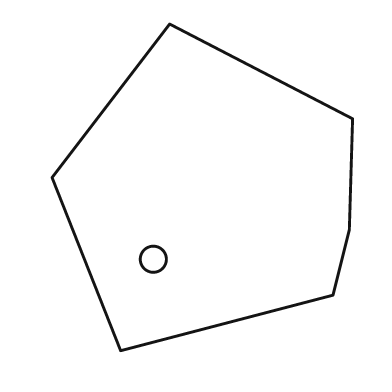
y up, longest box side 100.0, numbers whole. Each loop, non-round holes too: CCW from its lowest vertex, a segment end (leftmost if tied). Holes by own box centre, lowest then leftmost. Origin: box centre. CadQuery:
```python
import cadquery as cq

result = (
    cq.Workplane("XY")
    .moveTo(-25.0, -50.0)
    .lineTo(40.0, -33.0)
    .lineTo(45.0, -13.0)
    .lineTo(46.0, 21.0)
    .lineTo(-10.0, 50.0)
    .lineTo(-46.0, 3.0)
    .close()
    .moveTo(-15.0, -22.0)
    .circle(4.0)
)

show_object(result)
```